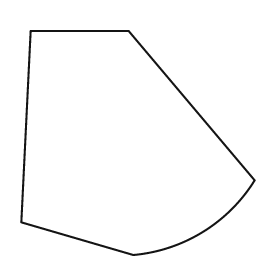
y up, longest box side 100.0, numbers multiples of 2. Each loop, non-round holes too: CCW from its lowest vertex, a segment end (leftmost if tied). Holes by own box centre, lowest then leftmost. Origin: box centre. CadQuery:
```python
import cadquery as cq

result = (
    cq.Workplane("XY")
    .moveTo(-2.0, -48.0)
    .threePointArc((28.0, -38.0), (50.0, -16.0))
    .lineTo(-4.0, 48.0)
    .lineTo(-46.0, 48.0)
    .lineTo(-50.0, -34.0)
    .close()
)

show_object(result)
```